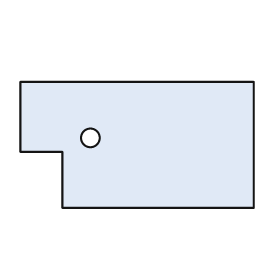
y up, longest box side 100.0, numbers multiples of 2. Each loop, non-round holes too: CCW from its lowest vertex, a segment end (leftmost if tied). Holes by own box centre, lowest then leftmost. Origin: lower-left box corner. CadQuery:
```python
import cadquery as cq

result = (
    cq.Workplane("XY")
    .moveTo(18.0, 0.0)
    .lineTo(100.0, 0.0)
    .lineTo(100.0, 54.0)
    .lineTo(0.0, 54.0)
    .lineTo(0.0, 24.0)
    .lineTo(18.0, 24.0)
    .close()
    .moveTo(30.0, 30.0)
    .circle(4.0)
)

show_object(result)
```